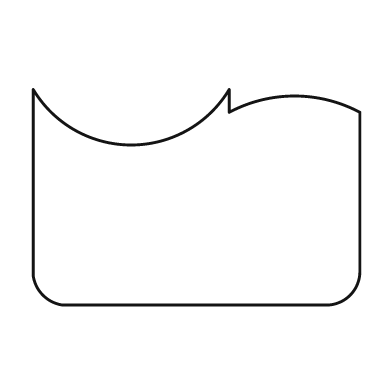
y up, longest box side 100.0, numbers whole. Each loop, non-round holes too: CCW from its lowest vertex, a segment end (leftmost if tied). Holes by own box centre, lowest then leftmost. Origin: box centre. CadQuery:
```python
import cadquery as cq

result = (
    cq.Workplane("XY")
    .moveTo(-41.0, -33.0)
    .lineTo(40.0, -33.0)
    .threePointArc((47.0, -30.0), (50.0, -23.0))
    .lineTo(50.0, 26.0)
    .threePointArc((30.0, 31.0), (10.0, 26.0))
    .lineTo(10.0, 33.0)
    .threePointArc((-20.0, 16.0), (-50.0, 33.0))
    .lineTo(-50.0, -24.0)
    .threePointArc((-47.0, -30.0), (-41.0, -33.0))
    .close()
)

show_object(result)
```